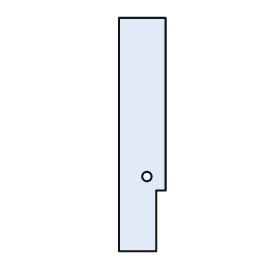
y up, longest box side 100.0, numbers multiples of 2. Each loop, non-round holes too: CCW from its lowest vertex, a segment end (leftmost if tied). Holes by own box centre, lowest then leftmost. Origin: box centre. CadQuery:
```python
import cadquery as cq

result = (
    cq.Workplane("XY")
    .moveTo(-10.0, -50.0)
    .lineTo(6.0, -50.0)
    .lineTo(6.0, -24.0)
    .lineTo(10.0, -24.0)
    .lineTo(10.0, 50.0)
    .lineTo(-10.0, 50.0)
    .close()
    .moveTo(2.0, -18.0)
    .circle(2.0)
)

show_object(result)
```